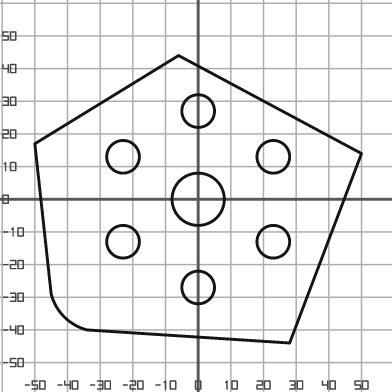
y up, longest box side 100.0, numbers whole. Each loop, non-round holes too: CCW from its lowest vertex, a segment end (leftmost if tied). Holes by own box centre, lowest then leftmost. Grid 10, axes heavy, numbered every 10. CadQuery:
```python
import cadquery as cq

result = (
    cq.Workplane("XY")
    .moveTo(28.0, -44.0)
    .lineTo(50.0, 14.0)
    .lineTo(-6.0, 44.0)
    .lineTo(-50.0, 17.0)
    .lineTo(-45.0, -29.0)
    .threePointArc((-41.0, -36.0), (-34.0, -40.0))
    .close()
    .moveTo(0.0, -27.0)
    .circle(5.0)
    .moveTo(-23.0, -13.0)
    .circle(5.0)
    .moveTo(23.0, -13.0)
    .circle(5.0)
    .moveTo(0.0, 0.0)
    .circle(8.0)
    .moveTo(-23.0, 13.0)
    .circle(5.0)
    .moveTo(23.0, 13.0)
    .circle(5.0)
    .moveTo(0.0, 27.0)
    .circle(5.0)
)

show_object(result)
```